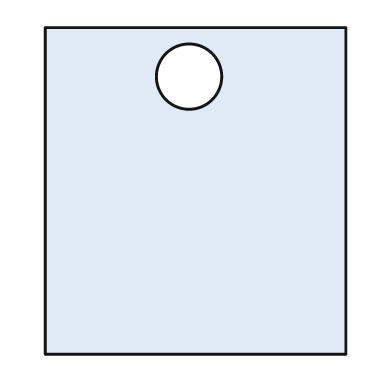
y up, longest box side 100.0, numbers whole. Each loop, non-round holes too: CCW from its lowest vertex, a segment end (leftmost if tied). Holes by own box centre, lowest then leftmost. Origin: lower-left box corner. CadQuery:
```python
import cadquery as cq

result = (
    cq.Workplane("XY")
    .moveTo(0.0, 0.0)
    .lineTo(92.0, 0.0)
    .lineTo(92.0, 100.0)
    .lineTo(0.0, 100.0)
    .close()
    .moveTo(44.0, 85.0)
    .circle(10.0)
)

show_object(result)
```